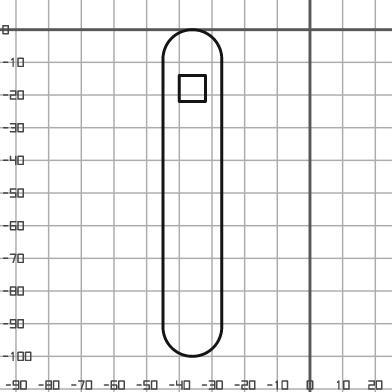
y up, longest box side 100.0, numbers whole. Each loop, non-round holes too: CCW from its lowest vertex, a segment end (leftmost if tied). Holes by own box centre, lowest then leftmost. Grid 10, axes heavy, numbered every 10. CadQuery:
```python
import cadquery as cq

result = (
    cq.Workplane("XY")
    .moveTo(-45.0, -91.0)
    .threePointArc((-36.0, -100.0), (-27.0, -91.0))
    .lineTo(-27.0, -9.0)
    .threePointArc((-36.0, 0.0), (-45.0, -9.0))
    .close()
    .moveTo(-40.0, -22.0)
    .lineTo(-32.0, -22.0)
    .lineTo(-32.0, -14.0)
    .lineTo(-40.0, -14.0)
    .close()
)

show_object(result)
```